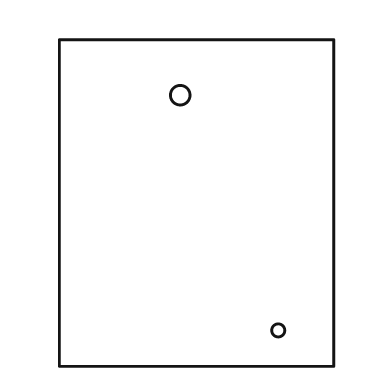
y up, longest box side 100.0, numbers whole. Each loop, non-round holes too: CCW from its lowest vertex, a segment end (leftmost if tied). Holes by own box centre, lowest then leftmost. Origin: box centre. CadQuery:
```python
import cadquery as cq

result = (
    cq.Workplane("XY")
    .moveTo(-42.0, -50.0)
    .lineTo(42.0, -50.0)
    .lineTo(42.0, 50.0)
    .lineTo(-42.0, 50.0)
    .close()
    .moveTo(25.0, -39.0)
    .circle(2.0)
    .moveTo(-5.0, 33.0)
    .circle(3.0)
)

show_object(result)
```